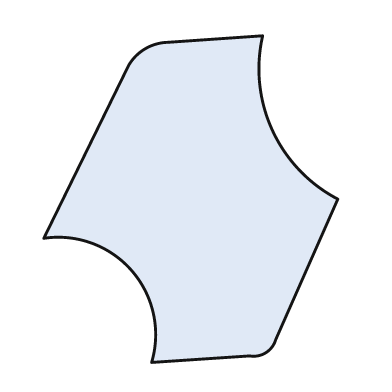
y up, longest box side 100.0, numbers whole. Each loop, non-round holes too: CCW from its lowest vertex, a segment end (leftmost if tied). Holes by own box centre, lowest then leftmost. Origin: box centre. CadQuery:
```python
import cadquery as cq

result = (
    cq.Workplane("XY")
    .moveTo(-12.0, -50.0)
    .lineTo(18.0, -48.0)
    .threePointArc((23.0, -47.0), (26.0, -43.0))
    .lineTo(45.0, 0.0)
    .threePointArc((25.0, 21.0), (22.0, 50.0))
    .lineTo(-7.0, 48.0)
    .threePointArc((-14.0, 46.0), (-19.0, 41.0))
    .lineTo(-45.0, -12.0)
    .threePointArc((-18.0, -22.0), (-12.0, -50.0))
    .close()
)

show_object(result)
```